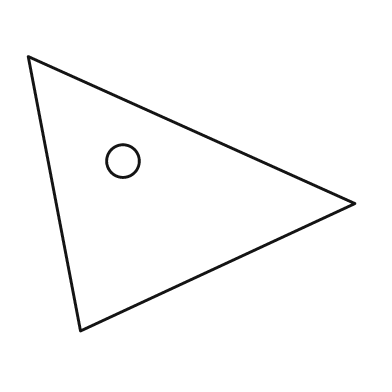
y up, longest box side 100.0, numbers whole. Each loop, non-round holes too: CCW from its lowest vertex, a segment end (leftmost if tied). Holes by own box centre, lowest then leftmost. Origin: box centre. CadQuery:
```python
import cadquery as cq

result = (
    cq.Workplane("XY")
    .moveTo(-34.0, -42.0)
    .lineTo(50.0, -3.0)
    .lineTo(-50.0, 42.0)
    .close()
    .moveTo(-21.0, 10.0)
    .circle(5.0)
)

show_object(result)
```